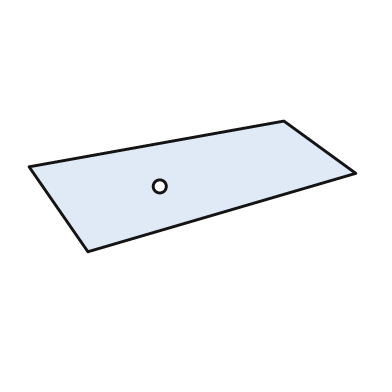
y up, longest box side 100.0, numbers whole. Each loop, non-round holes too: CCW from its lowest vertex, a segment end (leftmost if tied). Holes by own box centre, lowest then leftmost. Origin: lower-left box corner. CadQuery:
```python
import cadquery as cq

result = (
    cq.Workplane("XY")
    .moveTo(18.0, 0.0)
    .lineTo(100.0, 24.0)
    .lineTo(78.0, 40.0)
    .lineTo(0.0, 26.0)
    .close()
    .moveTo(40.0, 20.0)
    .circle(2.0)
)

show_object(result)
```